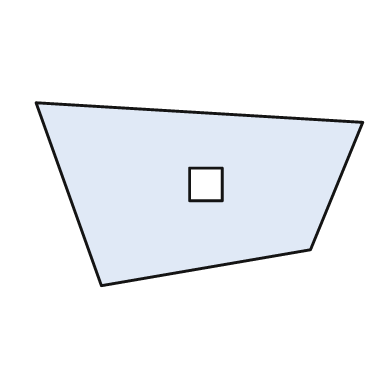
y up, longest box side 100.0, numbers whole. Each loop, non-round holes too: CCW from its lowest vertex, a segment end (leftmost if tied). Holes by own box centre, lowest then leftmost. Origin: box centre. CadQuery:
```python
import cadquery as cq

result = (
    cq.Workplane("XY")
    .moveTo(-30.0, -28.0)
    .lineTo(34.0, -17.0)
    .lineTo(50.0, 22.0)
    .lineTo(-50.0, 28.0)
    .close()
    .moveTo(-3.0, -2.0)
    .lineTo(7.0, -2.0)
    .lineTo(7.0, 8.0)
    .lineTo(-3.0, 8.0)
    .close()
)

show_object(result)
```